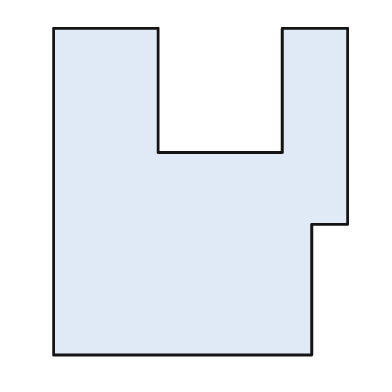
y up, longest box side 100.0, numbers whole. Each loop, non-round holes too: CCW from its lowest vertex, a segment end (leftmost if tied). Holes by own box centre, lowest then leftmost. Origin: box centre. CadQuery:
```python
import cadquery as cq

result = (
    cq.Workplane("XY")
    .moveTo(-45.0, -50.0)
    .lineTo(34.0, -50.0)
    .lineTo(34.0, -10.0)
    .lineTo(45.0, -10.0)
    .lineTo(45.0, 50.0)
    .lineTo(25.0, 50.0)
    .lineTo(25.0, 12.0)
    .lineTo(-13.0, 12.0)
    .lineTo(-13.0, 50.0)
    .lineTo(-45.0, 50.0)
    .close()
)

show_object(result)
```